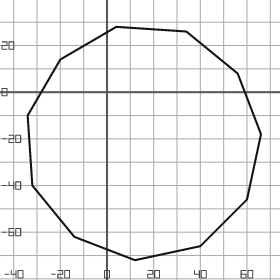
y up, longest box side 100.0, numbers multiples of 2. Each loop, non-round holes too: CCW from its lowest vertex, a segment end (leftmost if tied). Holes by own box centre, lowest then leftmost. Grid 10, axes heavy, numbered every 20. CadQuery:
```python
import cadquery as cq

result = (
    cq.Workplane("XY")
    .moveTo(12.0, -72.0)
    .lineTo(40.0, -66.0)
    .lineTo(60.0, -46.0)
    .lineTo(66.0, -18.0)
    .lineTo(56.0, 8.0)
    .lineTo(34.0, 26.0)
    .lineTo(4.0, 28.0)
    .lineTo(-20.0, 14.0)
    .lineTo(-34.0, -10.0)
    .lineTo(-32.0, -40.0)
    .lineTo(-14.0, -62.0)
    .close()
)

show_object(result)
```